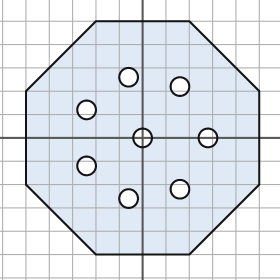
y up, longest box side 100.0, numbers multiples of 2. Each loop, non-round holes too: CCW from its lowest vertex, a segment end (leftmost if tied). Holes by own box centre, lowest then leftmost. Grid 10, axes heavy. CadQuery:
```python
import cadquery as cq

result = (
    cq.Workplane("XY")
    .moveTo(-20.0, -50.0)
    .lineTo(20.0, -50.0)
    .lineTo(50.0, -20.0)
    .lineTo(50.0, 20.0)
    .lineTo(20.0, 50.0)
    .lineTo(-20.0, 50.0)
    .lineTo(-50.0, 20.0)
    .lineTo(-50.0, -20.0)
    .close()
    .moveTo(-6.0, -26.0)
    .circle(4.0)
    .moveTo(16.0, -22.0)
    .circle(4.0)
    .moveTo(-24.0, -12.0)
    .circle(4.0)
    .moveTo(0.0, 0.0)
    .circle(4.0)
    .moveTo(28.0, 0.0)
    .circle(4.0)
    .moveTo(-24.0, 12.0)
    .circle(4.0)
    .moveTo(16.0, 22.0)
    .circle(4.0)
    .moveTo(-6.0, 26.0)
    .circle(4.0)
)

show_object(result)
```